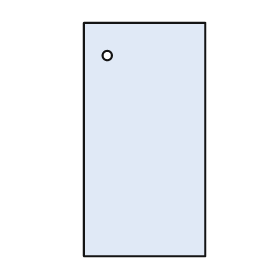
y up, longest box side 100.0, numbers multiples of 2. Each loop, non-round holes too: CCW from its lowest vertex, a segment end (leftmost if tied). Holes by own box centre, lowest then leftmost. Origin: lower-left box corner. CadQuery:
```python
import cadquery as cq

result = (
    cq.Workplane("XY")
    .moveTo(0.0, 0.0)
    .lineTo(52.0, 0.0)
    .lineTo(52.0, 100.0)
    .lineTo(0.0, 100.0)
    .close()
    .moveTo(10.0, 86.0)
    .circle(2.0)
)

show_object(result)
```